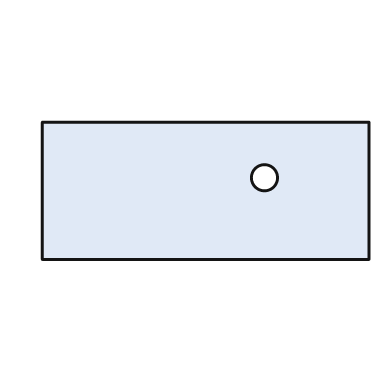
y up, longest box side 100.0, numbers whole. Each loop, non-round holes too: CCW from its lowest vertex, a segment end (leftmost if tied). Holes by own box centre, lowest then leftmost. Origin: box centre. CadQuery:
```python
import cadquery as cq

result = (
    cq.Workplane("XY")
    .moveTo(-50.0, -21.0)
    .lineTo(50.0, -21.0)
    .lineTo(50.0, 21.0)
    .lineTo(-50.0, 21.0)
    .close()
    .moveTo(18.0, 4.0)
    .circle(4.0)
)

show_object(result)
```